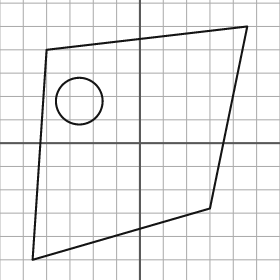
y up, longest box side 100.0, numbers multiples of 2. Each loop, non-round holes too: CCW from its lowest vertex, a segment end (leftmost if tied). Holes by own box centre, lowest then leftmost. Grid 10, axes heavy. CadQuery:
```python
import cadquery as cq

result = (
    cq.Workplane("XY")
    .moveTo(-46.0, -50.0)
    .lineTo(30.0, -28.0)
    .lineTo(46.0, 50.0)
    .lineTo(-40.0, 40.0)
    .close()
    .moveTo(-26.0, 18.0)
    .circle(10.0)
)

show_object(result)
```